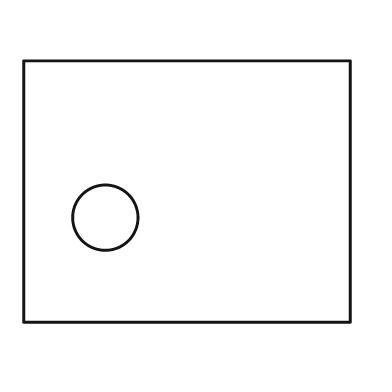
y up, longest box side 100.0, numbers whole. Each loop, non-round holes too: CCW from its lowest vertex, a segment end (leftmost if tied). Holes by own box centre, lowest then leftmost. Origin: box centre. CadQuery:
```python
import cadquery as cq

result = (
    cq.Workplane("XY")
    .moveTo(-50.0, -40.0)
    .lineTo(50.0, -40.0)
    .lineTo(50.0, 40.0)
    .lineTo(-50.0, 40.0)
    .close()
    .moveTo(-25.0, -8.0)
    .circle(10.0)
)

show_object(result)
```